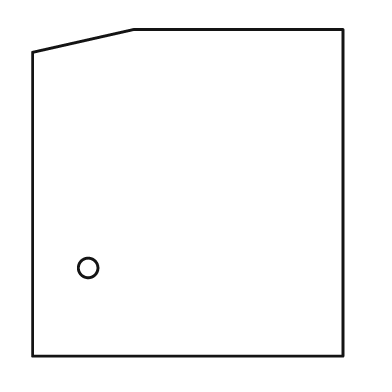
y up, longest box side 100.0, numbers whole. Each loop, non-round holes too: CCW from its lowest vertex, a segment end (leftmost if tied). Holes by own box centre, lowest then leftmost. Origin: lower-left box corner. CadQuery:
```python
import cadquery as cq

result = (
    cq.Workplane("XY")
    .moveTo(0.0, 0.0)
    .lineTo(95.0, 0.0)
    .lineTo(95.0, 100.0)
    .lineTo(31.0, 100.0)
    .lineTo(0.0, 93.0)
    .close()
    .moveTo(17.0, 27.0)
    .circle(3.0)
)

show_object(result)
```